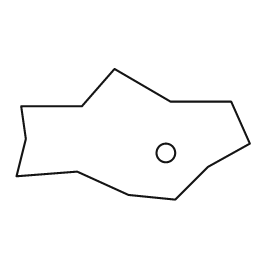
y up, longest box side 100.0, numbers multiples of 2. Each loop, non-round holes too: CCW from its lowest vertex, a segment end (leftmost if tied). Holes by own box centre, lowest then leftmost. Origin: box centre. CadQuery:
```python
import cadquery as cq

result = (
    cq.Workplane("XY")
    .moveTo(18.0, -28.0)
    .lineTo(32.0, -14.0)
    .lineTo(50.0, -4.0)
    .lineTo(42.0, 14.0)
    .lineTo(16.0, 14.0)
    .lineTo(-8.0, 28.0)
    .lineTo(-22.0, 12.0)
    .lineTo(-48.0, 12.0)
    .lineTo(-46.0, -2.0)
    .lineTo(-50.0, -18.0)
    .lineTo(-24.0, -16.0)
    .lineTo(-2.0, -26.0)
    .close()
    .moveTo(14.0, -8.0)
    .circle(4.0)
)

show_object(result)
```